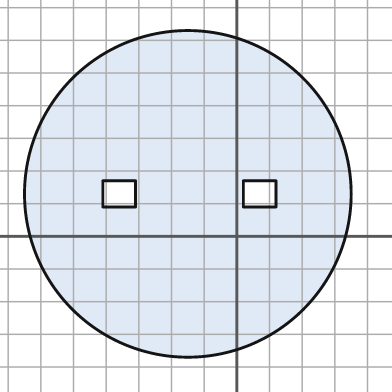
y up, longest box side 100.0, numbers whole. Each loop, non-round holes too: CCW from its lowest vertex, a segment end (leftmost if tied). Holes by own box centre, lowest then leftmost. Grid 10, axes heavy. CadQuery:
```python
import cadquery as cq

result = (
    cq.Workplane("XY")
    .moveTo(-15.0, 13.0)
    .circle(50.0)
    .moveTo(-41.0, 9.0)
    .lineTo(-31.0, 9.0)
    .lineTo(-31.0, 17.0)
    .lineTo(-41.0, 17.0)
    .close()
    .moveTo(2.0, 9.0)
    .lineTo(12.0, 9.0)
    .lineTo(12.0, 17.0)
    .lineTo(2.0, 17.0)
    .close()
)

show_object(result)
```